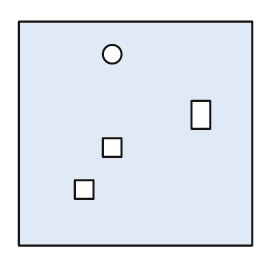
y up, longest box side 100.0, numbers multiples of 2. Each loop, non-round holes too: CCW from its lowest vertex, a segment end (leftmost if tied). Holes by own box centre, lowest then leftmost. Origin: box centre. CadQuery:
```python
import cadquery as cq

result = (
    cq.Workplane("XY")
    .moveTo(-50.0, -48.0)
    .lineTo(50.0, -48.0)
    .lineTo(50.0, 48.0)
    .lineTo(-50.0, 48.0)
    .close()
    .moveTo(-26.0, -28.0)
    .lineTo(-18.0, -28.0)
    .lineTo(-18.0, -20.0)
    .lineTo(-26.0, -20.0)
    .close()
    .moveTo(-14.0, -10.0)
    .lineTo(-6.0, -10.0)
    .lineTo(-6.0, -2.0)
    .lineTo(-14.0, -2.0)
    .close()
    .moveTo(24.0, 2.0)
    .lineTo(32.0, 2.0)
    .lineTo(32.0, 14.0)
    .lineTo(24.0, 14.0)
    .close()
    .moveTo(-10.0, 34.0)
    .circle(4.0)
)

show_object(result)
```